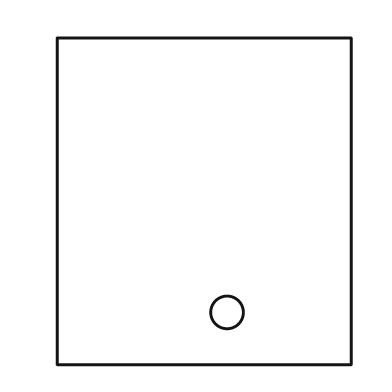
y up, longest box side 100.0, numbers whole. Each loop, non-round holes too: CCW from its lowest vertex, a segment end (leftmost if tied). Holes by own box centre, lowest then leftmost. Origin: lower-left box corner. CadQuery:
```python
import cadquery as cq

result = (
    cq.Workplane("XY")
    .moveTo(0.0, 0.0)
    .lineTo(90.0, 0.0)
    .lineTo(90.0, 100.0)
    .lineTo(0.0, 100.0)
    .close()
    .moveTo(52.0, 16.0)
    .circle(5.0)
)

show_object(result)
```